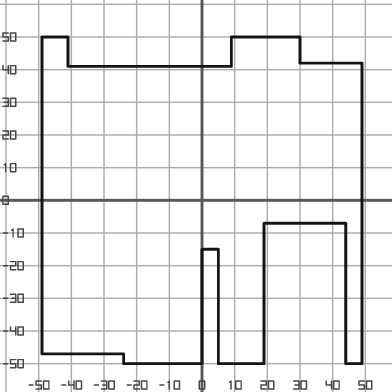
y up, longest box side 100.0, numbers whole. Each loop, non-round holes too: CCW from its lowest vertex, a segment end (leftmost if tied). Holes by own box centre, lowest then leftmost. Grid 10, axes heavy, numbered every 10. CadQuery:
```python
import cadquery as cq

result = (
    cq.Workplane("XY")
    .moveTo(-24.0, -50.0)
    .lineTo(0.0, -50.0)
    .lineTo(0.0, -15.0)
    .lineTo(5.0, -15.0)
    .lineTo(5.0, -50.0)
    .lineTo(19.0, -50.0)
    .lineTo(19.0, -7.0)
    .lineTo(44.0, -7.0)
    .lineTo(44.0, -50.0)
    .lineTo(49.0, -50.0)
    .lineTo(49.0, 42.0)
    .lineTo(30.0, 42.0)
    .lineTo(30.0, 50.0)
    .lineTo(9.0, 50.0)
    .lineTo(9.0, 41.0)
    .lineTo(-41.0, 41.0)
    .lineTo(-41.0, 50.0)
    .lineTo(-49.0, 50.0)
    .lineTo(-49.0, -47.0)
    .lineTo(-24.0, -47.0)
    .close()
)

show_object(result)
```